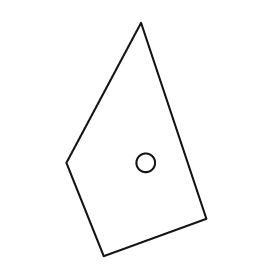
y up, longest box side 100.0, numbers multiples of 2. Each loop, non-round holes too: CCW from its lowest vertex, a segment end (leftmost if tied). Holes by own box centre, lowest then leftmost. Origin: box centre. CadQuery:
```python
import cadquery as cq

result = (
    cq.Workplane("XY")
    .moveTo(-14.0, -50.0)
    .lineTo(30.0, -34.0)
    .lineTo(2.0, 50.0)
    .lineTo(-30.0, -10.0)
    .close()
    .moveTo(4.0, -10.0)
    .circle(4.0)
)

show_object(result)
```